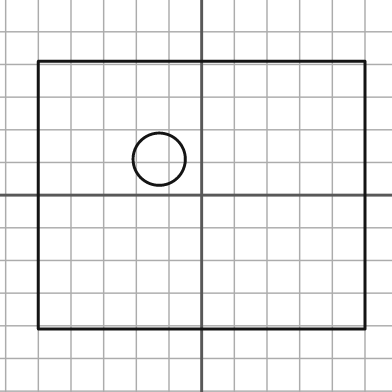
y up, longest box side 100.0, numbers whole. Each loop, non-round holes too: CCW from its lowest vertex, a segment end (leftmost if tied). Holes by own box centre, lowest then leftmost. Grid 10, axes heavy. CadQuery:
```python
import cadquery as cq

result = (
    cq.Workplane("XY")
    .moveTo(-50.0, -41.0)
    .lineTo(50.0, -41.0)
    .lineTo(50.0, 41.0)
    .lineTo(-50.0, 41.0)
    .close()
    .moveTo(-13.0, 11.0)
    .circle(8.0)
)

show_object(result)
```